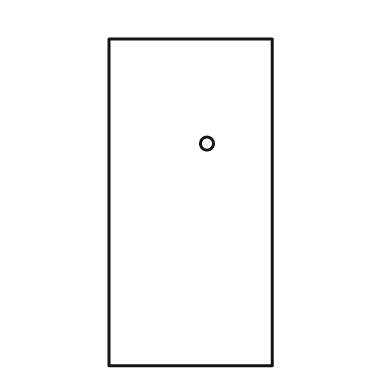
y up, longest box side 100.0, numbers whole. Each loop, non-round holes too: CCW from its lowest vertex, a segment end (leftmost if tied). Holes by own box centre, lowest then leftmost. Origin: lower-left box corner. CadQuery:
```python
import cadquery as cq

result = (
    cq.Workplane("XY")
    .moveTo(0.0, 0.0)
    .lineTo(50.0, 0.0)
    .lineTo(50.0, 100.0)
    .lineTo(0.0, 100.0)
    .close()
    .moveTo(30.0, 68.0)
    .circle(2.0)
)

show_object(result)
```